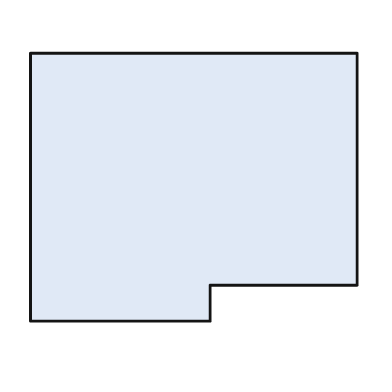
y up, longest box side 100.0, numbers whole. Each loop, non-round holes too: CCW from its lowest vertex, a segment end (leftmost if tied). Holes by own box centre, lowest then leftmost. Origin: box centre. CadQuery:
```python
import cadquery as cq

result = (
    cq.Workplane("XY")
    .moveTo(-50.0, -41.0)
    .lineTo(5.0, -41.0)
    .lineTo(5.0, -30.0)
    .lineTo(50.0, -30.0)
    .lineTo(50.0, 41.0)
    .lineTo(-50.0, 41.0)
    .close()
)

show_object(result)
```